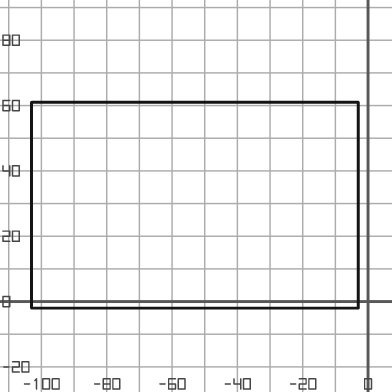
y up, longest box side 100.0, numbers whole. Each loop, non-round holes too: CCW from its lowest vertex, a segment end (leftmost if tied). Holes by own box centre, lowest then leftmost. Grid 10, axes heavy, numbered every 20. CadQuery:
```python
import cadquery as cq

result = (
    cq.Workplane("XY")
    .moveTo(-103.0, -2.0)
    .lineTo(-3.0, -2.0)
    .lineTo(-3.0, 61.0)
    .lineTo(-103.0, 61.0)
    .close()
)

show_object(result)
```